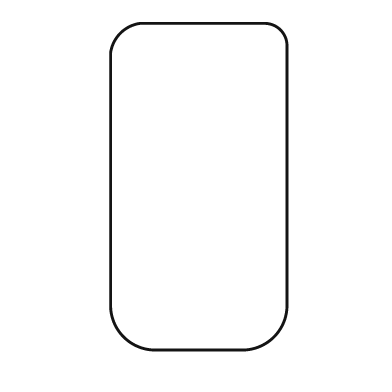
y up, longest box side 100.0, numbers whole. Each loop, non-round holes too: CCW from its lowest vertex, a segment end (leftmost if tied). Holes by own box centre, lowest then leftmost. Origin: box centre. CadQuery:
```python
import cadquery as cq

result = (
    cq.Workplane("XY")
    .moveTo(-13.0, -50.0)
    .lineTo(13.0, -50.0)
    .threePointArc((23.0, -46.0), (27.0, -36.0))
    .lineTo(27.0, 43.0)
    .threePointArc((25.0, 48.0), (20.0, 50.0))
    .lineTo(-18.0, 50.0)
    .threePointArc((-24.0, 47.0), (-27.0, 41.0))
    .lineTo(-27.0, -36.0)
    .threePointArc((-23.0, -46.0), (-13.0, -50.0))
    .close()
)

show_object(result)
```